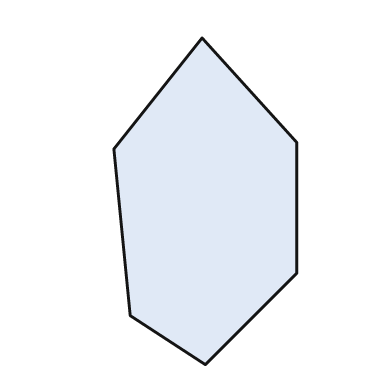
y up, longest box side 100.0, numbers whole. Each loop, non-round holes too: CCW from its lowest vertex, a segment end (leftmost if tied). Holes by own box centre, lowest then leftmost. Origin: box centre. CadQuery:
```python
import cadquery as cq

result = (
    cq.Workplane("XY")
    .moveTo(0.0, -50.0)
    .lineTo(28.0, -22.0)
    .lineTo(28.0, 18.0)
    .lineTo(-1.0, 50.0)
    .lineTo(-28.0, 16.0)
    .lineTo(-23.0, -35.0)
    .close()
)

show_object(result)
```